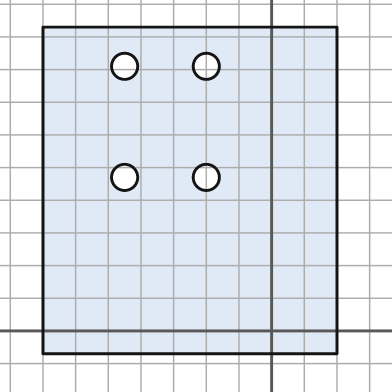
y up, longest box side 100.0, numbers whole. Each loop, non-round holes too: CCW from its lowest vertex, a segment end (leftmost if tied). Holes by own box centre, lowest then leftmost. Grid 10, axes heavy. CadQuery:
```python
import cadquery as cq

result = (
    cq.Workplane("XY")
    .moveTo(-70.0, -7.0)
    .lineTo(20.0, -7.0)
    .lineTo(20.0, 93.0)
    .lineTo(-70.0, 93.0)
    .close()
    .moveTo(-45.0, 47.0)
    .circle(4.0)
    .moveTo(-20.0, 47.0)
    .circle(4.0)
    .moveTo(-45.0, 81.0)
    .circle(4.0)
    .moveTo(-20.0, 81.0)
    .circle(4.0)
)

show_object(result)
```